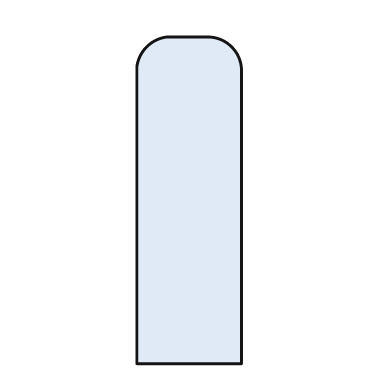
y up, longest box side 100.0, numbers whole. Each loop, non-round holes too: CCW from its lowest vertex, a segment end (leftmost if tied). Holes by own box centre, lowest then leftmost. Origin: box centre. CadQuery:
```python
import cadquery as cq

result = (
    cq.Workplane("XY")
    .moveTo(-16.0, -50.0)
    .lineTo(16.0, -50.0)
    .lineTo(16.0, 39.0)
    .threePointArc((13.0, 47.0), (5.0, 50.0))
    .lineTo(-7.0, 50.0)
    .threePointArc((-13.0, 47.0), (-16.0, 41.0))
    .close()
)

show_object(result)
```